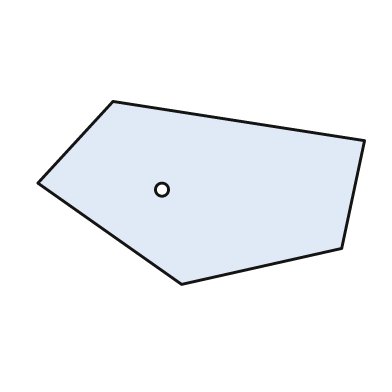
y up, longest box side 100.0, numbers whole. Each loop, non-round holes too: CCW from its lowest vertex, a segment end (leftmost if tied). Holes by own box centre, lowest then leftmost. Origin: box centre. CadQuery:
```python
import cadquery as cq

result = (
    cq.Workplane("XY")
    .moveTo(-6.0, -28.0)
    .lineTo(43.0, -17.0)
    .lineTo(50.0, 16.0)
    .lineTo(-27.0, 28.0)
    .lineTo(-50.0, 3.0)
    .close()
    .moveTo(-12.0, 1.0)
    .circle(2.0)
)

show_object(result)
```